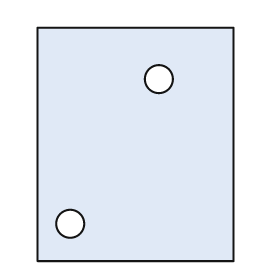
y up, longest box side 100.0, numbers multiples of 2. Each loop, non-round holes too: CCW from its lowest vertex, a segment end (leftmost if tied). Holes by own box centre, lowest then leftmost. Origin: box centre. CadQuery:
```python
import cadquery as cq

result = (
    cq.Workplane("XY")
    .moveTo(-42.0, -50.0)
    .lineTo(42.0, -50.0)
    .lineTo(42.0, 50.0)
    .lineTo(-42.0, 50.0)
    .close()
    .moveTo(-28.0, -34.0)
    .circle(6.0)
    .moveTo(10.0, 28.0)
    .circle(6.0)
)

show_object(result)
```